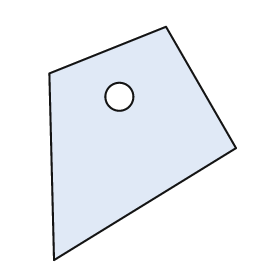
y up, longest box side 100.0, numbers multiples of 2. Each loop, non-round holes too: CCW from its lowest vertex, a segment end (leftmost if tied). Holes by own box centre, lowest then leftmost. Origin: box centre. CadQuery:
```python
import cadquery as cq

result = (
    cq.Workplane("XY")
    .moveTo(-38.0, -50.0)
    .lineTo(40.0, -2.0)
    .lineTo(10.0, 50.0)
    .lineTo(-40.0, 30.0)
    .close()
    .moveTo(-10.0, 20.0)
    .circle(6.0)
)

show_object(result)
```